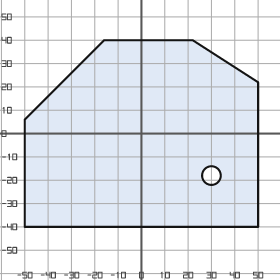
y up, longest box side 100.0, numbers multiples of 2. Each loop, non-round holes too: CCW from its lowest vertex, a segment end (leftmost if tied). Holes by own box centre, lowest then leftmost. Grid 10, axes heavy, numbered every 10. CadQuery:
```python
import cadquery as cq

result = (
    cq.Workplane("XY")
    .moveTo(-50.0, -40.0)
    .lineTo(50.0, -40.0)
    .lineTo(50.0, 22.0)
    .lineTo(22.0, 40.0)
    .lineTo(-16.0, 40.0)
    .lineTo(-50.0, 6.0)
    .close()
    .moveTo(30.0, -18.0)
    .circle(4.0)
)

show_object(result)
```